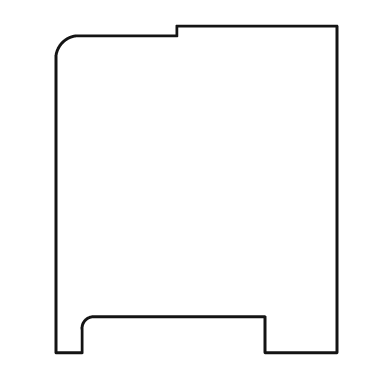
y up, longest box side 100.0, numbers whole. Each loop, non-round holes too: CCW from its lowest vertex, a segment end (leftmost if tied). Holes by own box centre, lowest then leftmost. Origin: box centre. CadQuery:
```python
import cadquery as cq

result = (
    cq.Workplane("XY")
    .moveTo(-43.0, -50.0)
    .lineTo(-35.0, -50.0)
    .lineTo(-35.0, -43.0)
    .threePointArc((-34.0, -40.0), (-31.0, -39.0))
    .lineTo(21.0, -39.0)
    .lineTo(21.0, -50.0)
    .lineTo(43.0, -50.0)
    .lineTo(43.0, 50.0)
    .lineTo(-6.0, 50.0)
    .lineTo(-6.0, 47.0)
    .lineTo(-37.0, 47.0)
    .threePointArc((-41.0, 45.0), (-43.0, 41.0))
    .close()
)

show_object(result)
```